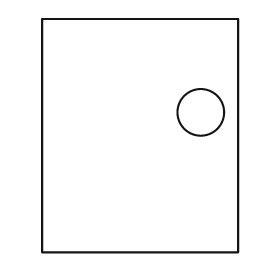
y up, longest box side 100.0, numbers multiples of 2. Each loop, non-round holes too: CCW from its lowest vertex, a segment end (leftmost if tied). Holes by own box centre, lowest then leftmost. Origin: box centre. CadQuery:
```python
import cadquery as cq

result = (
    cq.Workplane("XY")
    .moveTo(-42.0, -50.0)
    .lineTo(42.0, -50.0)
    .lineTo(42.0, 50.0)
    .lineTo(-42.0, 50.0)
    .close()
    .moveTo(26.0, 10.0)
    .circle(10.0)
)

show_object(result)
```